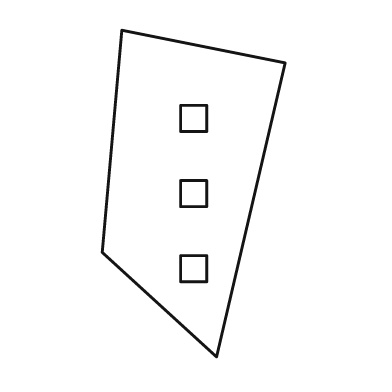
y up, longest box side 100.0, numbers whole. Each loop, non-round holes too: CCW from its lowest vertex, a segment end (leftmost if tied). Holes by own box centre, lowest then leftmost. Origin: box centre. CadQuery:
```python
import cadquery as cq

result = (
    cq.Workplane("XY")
    .moveTo(7.0, -50.0)
    .lineTo(28.0, 40.0)
    .lineTo(-22.0, 50.0)
    .lineTo(-28.0, -18.0)
    .close()
    .moveTo(-4.0, -27.0)
    .lineTo(4.0, -27.0)
    .lineTo(4.0, -19.0)
    .lineTo(-4.0, -19.0)
    .close()
    .moveTo(-4.0, -4.0)
    .lineTo(4.0, -4.0)
    .lineTo(4.0, 4.0)
    .lineTo(-4.0, 4.0)
    .close()
    .moveTo(-4.0, 19.0)
    .lineTo(4.0, 19.0)
    .lineTo(4.0, 27.0)
    .lineTo(-4.0, 27.0)
    .close()
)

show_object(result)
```